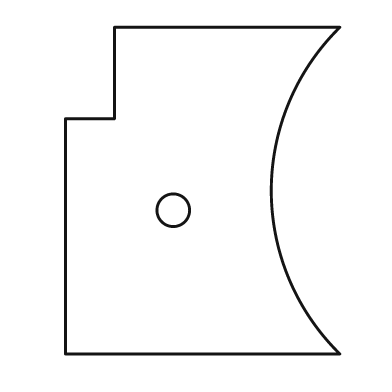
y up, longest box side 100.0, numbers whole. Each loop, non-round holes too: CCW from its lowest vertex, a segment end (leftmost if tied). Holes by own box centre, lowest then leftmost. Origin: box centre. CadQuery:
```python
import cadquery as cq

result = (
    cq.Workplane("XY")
    .moveTo(-42.0, -50.0)
    .lineTo(42.0, -50.0)
    .threePointArc((21.0, 0.0), (42.0, 50.0))
    .lineTo(-27.0, 50.0)
    .lineTo(-27.0, 22.0)
    .lineTo(-42.0, 22.0)
    .close()
    .moveTo(-9.0, -6.0)
    .circle(5.0)
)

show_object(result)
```